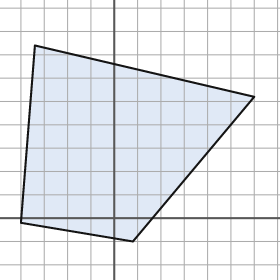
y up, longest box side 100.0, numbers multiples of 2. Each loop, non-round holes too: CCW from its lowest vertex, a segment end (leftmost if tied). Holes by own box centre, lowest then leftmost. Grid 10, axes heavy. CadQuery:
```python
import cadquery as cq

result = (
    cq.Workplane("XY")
    .moveTo(8.0, -10.0)
    .lineTo(60.0, 52.0)
    .lineTo(-34.0, 74.0)
    .lineTo(-40.0, -2.0)
    .close()
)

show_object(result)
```